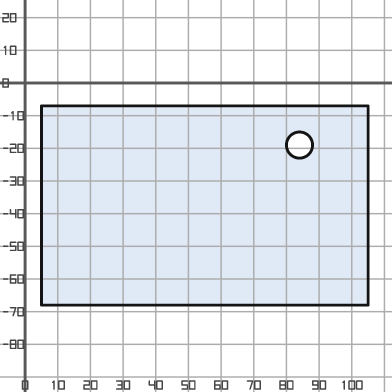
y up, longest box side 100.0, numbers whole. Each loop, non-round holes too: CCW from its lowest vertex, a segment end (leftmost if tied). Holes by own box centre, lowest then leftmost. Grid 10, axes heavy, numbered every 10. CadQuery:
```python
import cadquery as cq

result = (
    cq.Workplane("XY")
    .moveTo(5.0, -68.0)
    .lineTo(105.0, -68.0)
    .lineTo(105.0, -7.0)
    .lineTo(5.0, -7.0)
    .close()
    .moveTo(84.0, -19.0)
    .circle(4.0)
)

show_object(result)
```